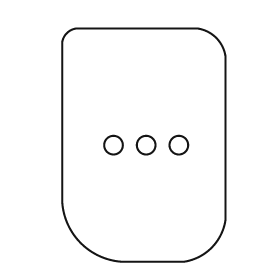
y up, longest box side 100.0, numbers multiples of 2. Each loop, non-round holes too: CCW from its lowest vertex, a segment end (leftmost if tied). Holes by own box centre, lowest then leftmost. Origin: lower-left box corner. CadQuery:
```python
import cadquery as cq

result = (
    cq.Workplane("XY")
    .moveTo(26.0, 0.0)
    .lineTo(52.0, 0.0)
    .threePointArc((64.0, 6.0), (70.0, 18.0))
    .lineTo(70.0, 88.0)
    .threePointArc((66.0, 96.0), (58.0, 100.0))
    .lineTo(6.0, 100.0)
    .threePointArc((2.0, 98.0), (0.0, 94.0))
    .lineTo(0.0, 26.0)
    .threePointArc((8.0, 8.0), (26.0, 0.0))
    .close()
    .moveTo(22.0, 50.0)
    .circle(4.0)
    .moveTo(36.0, 50.0)
    .circle(4.0)
    .moveTo(50.0, 50.0)
    .circle(4.0)
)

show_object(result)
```